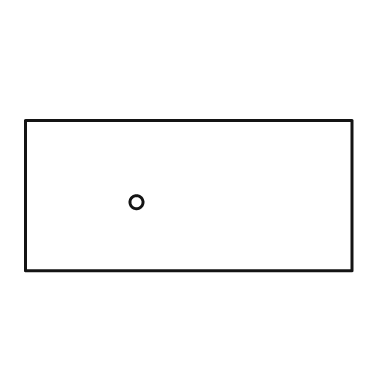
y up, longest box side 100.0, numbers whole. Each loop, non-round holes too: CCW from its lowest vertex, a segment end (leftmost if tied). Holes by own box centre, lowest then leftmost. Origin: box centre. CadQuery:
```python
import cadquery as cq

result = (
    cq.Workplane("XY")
    .moveTo(-50.0, -23.0)
    .lineTo(50.0, -23.0)
    .lineTo(50.0, 23.0)
    .lineTo(-50.0, 23.0)
    .close()
    .moveTo(-16.0, -2.0)
    .circle(2.0)
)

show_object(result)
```